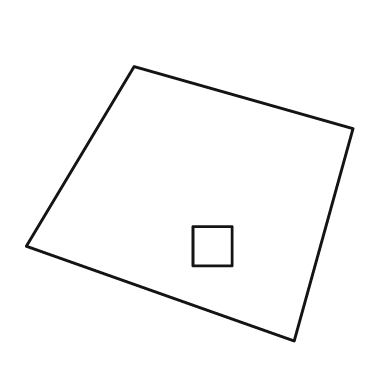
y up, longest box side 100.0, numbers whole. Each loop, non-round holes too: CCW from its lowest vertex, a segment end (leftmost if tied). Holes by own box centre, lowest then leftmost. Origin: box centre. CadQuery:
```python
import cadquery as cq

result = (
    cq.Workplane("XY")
    .moveTo(32.0, -42.0)
    .lineTo(50.0, 23.0)
    .lineTo(-17.0, 42.0)
    .lineTo(-50.0, -13.0)
    .close()
    .moveTo(1.0, -19.0)
    .lineTo(13.0, -19.0)
    .lineTo(13.0, -7.0)
    .lineTo(1.0, -7.0)
    .close()
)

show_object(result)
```